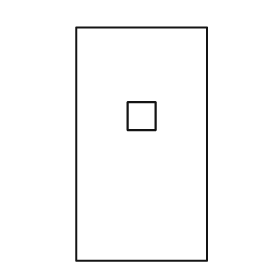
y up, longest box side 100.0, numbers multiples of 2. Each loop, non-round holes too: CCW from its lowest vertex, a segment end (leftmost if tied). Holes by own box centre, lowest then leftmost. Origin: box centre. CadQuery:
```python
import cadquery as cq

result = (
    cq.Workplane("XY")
    .moveTo(-28.0, -50.0)
    .lineTo(28.0, -50.0)
    .lineTo(28.0, 50.0)
    .lineTo(-28.0, 50.0)
    .close()
    .moveTo(-6.0, 6.0)
    .lineTo(6.0, 6.0)
    .lineTo(6.0, 18.0)
    .lineTo(-6.0, 18.0)
    .close()
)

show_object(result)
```